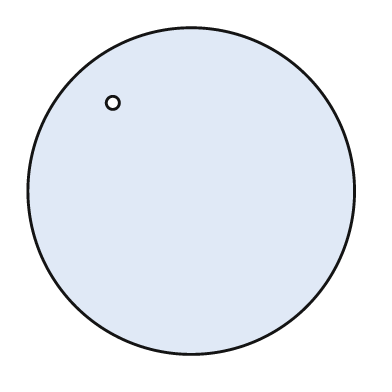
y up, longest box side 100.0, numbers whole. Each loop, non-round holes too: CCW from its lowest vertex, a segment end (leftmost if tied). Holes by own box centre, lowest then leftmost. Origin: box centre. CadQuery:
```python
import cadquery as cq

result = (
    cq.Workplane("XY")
    .moveTo(0.0, 0.0)
    .circle(50.0)
    .moveTo(-24.0, 27.0)
    .circle(2.0)
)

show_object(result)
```